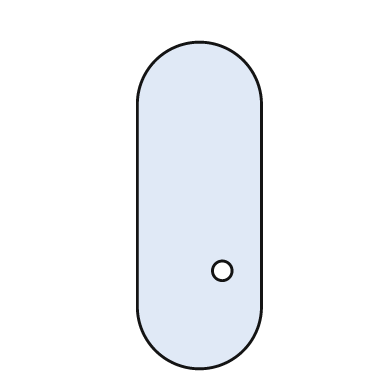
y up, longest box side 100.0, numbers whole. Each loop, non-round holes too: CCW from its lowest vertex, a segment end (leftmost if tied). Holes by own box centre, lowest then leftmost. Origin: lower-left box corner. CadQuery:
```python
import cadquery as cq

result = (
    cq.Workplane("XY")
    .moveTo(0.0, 19.0)
    .threePointArc((19.0, 0.0), (38.0, 19.0))
    .lineTo(38.0, 81.0)
    .threePointArc((19.0, 100.0), (0.0, 81.0))
    .close()
    .moveTo(26.0, 30.0)
    .circle(3.0)
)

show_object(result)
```